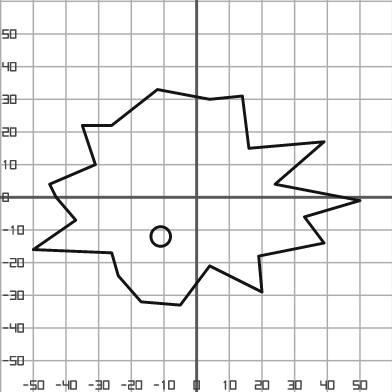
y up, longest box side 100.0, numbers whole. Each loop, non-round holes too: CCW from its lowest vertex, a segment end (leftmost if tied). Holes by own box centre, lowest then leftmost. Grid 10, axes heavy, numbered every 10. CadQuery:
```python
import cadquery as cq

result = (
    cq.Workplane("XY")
    .moveTo(-5.0, -33.0)
    .lineTo(4.0, -21.0)
    .lineTo(20.0, -29.0)
    .lineTo(19.0, -18.0)
    .lineTo(39.0, -14.0)
    .lineTo(33.0, -6.0)
    .lineTo(50.0, -1.0)
    .lineTo(24.0, 4.0)
    .lineTo(39.0, 17.0)
    .lineTo(16.0, 15.0)
    .lineTo(14.0, 31.0)
    .lineTo(4.0, 30.0)
    .lineTo(-12.0, 33.0)
    .lineTo(-26.0, 22.0)
    .lineTo(-35.0, 22.0)
    .lineTo(-31.0, 10.0)
    .lineTo(-45.0, 4.0)
    .lineTo(-43.0, 0.0)
    .lineTo(-37.0, -7.0)
    .lineTo(-50.0, -16.0)
    .lineTo(-26.0, -17.0)
    .lineTo(-24.0, -24.0)
    .lineTo(-17.0, -32.0)
    .close()
    .moveTo(-11.0, -12.0)
    .circle(3.0)
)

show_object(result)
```